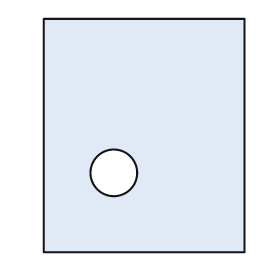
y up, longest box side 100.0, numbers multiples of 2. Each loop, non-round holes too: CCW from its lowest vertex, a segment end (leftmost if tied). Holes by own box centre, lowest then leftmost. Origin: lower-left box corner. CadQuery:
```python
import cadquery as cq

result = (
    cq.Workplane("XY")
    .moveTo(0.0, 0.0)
    .lineTo(86.0, 0.0)
    .lineTo(86.0, 100.0)
    .lineTo(0.0, 100.0)
    .close()
    .moveTo(30.0, 34.0)
    .circle(10.0)
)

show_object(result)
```